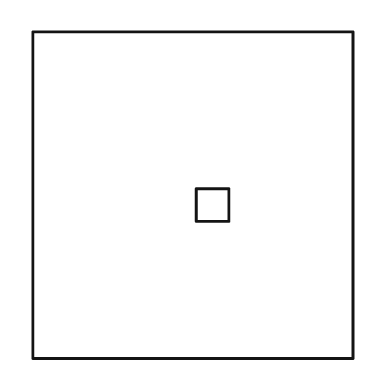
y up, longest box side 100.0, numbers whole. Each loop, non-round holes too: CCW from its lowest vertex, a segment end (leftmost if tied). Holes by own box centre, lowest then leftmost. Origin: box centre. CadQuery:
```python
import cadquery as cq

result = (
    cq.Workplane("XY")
    .moveTo(-49.0, -50.0)
    .lineTo(49.0, -50.0)
    .lineTo(49.0, 50.0)
    .lineTo(-49.0, 50.0)
    .close()
    .moveTo(1.0, -8.0)
    .lineTo(11.0, -8.0)
    .lineTo(11.0, 2.0)
    .lineTo(1.0, 2.0)
    .close()
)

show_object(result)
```